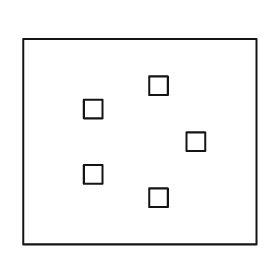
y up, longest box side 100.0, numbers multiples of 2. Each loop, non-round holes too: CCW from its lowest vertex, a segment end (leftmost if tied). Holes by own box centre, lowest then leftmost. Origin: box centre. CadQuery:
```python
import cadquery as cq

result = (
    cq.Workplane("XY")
    .moveTo(-50.0, -44.0)
    .lineTo(50.0, -44.0)
    .lineTo(50.0, 44.0)
    .lineTo(-50.0, 44.0)
    .close()
    .moveTo(4.0, -28.0)
    .lineTo(12.0, -28.0)
    .lineTo(12.0, -20.0)
    .lineTo(4.0, -20.0)
    .close()
    .moveTo(-24.0, -18.0)
    .lineTo(-16.0, -18.0)
    .lineTo(-16.0, -10.0)
    .lineTo(-24.0, -10.0)
    .close()
    .moveTo(20.0, -4.0)
    .lineTo(28.0, -4.0)
    .lineTo(28.0, 4.0)
    .lineTo(20.0, 4.0)
    .close()
    .moveTo(-24.0, 10.0)
    .lineTo(-16.0, 10.0)
    .lineTo(-16.0, 18.0)
    .lineTo(-24.0, 18.0)
    .close()
    .moveTo(4.0, 20.0)
    .lineTo(12.0, 20.0)
    .lineTo(12.0, 28.0)
    .lineTo(4.0, 28.0)
    .close()
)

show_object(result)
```